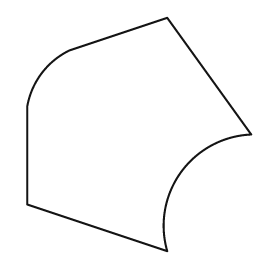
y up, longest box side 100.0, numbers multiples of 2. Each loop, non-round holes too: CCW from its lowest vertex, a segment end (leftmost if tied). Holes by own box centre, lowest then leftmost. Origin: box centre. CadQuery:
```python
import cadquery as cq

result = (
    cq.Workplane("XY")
    .moveTo(12.0, -50.0)
    .threePointArc((18.0, -16.0), (48.0, 0.0))
    .lineTo(12.0, 50.0)
    .lineTo(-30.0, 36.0)
    .threePointArc((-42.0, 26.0), (-48.0, 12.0))
    .lineTo(-48.0, -30.0)
    .close()
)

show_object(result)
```